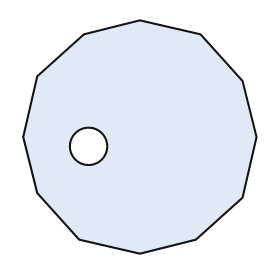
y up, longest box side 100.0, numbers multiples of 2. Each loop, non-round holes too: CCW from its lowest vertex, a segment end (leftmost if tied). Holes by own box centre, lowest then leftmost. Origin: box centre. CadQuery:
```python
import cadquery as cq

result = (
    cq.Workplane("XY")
    .moveTo(0.0, -50.0)
    .lineTo(24.0, -44.0)
    .lineTo(44.0, -26.0)
    .lineTo(50.0, 0.0)
    .lineTo(44.0, 24.0)
    .lineTo(26.0, 44.0)
    .lineTo(0.0, 50.0)
    .lineTo(-24.0, 44.0)
    .lineTo(-44.0, 26.0)
    .lineTo(-50.0, 0.0)
    .lineTo(-44.0, -24.0)
    .lineTo(-26.0, -44.0)
    .close()
    .moveTo(-22.0, -4.0)
    .circle(8.0)
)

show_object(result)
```